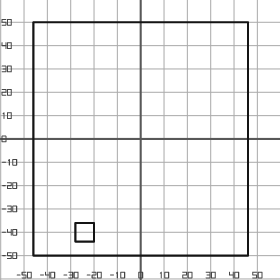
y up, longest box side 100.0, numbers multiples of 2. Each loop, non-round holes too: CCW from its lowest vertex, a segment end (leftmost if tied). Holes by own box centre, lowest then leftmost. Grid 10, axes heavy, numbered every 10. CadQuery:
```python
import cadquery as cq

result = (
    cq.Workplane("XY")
    .moveTo(-46.0, -50.0)
    .lineTo(46.0, -50.0)
    .lineTo(46.0, 50.0)
    .lineTo(-46.0, 50.0)
    .close()
    .moveTo(-28.0, -44.0)
    .lineTo(-20.0, -44.0)
    .lineTo(-20.0, -36.0)
    .lineTo(-28.0, -36.0)
    .close()
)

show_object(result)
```